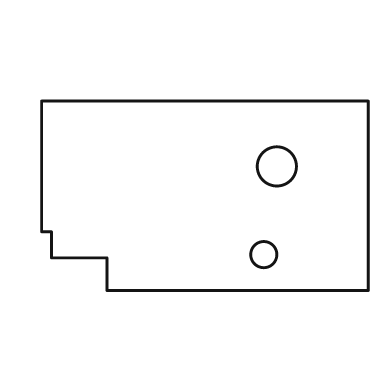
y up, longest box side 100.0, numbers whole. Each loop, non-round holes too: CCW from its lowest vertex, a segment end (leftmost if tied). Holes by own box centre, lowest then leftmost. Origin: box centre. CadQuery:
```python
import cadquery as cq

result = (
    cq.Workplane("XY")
    .moveTo(-30.0, -29.0)
    .lineTo(50.0, -29.0)
    .lineTo(50.0, 29.0)
    .lineTo(-50.0, 29.0)
    .lineTo(-50.0, -11.0)
    .lineTo(-47.0, -11.0)
    .lineTo(-47.0, -19.0)
    .lineTo(-30.0, -19.0)
    .close()
    .moveTo(18.0, -18.0)
    .circle(4.0)
    .moveTo(22.0, 9.0)
    .circle(6.0)
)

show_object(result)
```